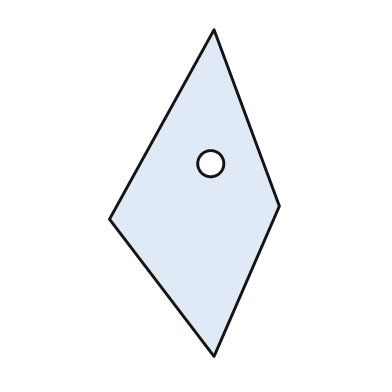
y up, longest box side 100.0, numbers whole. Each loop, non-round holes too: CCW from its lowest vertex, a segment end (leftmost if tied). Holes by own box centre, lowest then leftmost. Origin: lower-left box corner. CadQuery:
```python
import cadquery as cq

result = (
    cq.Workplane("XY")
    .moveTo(32.0, 0.0)
    .lineTo(52.0, 46.0)
    .lineTo(32.0, 100.0)
    .lineTo(0.0, 42.0)
    .close()
    .moveTo(31.0, 59.0)
    .circle(4.0)
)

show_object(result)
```